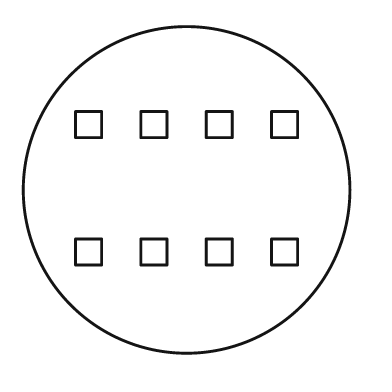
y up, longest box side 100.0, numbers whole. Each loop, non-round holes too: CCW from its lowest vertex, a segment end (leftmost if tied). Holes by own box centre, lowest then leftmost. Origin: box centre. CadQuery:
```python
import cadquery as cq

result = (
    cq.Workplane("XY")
    .moveTo(0.0, 0.0)
    .circle(50.0)
    .moveTo(-34.0, -23.0)
    .lineTo(-26.0, -23.0)
    .lineTo(-26.0, -15.0)
    .lineTo(-34.0, -15.0)
    .close()
    .moveTo(-14.0, -23.0)
    .lineTo(-6.0, -23.0)
    .lineTo(-6.0, -15.0)
    .lineTo(-14.0, -15.0)
    .close()
    .moveTo(6.0, -23.0)
    .lineTo(14.0, -23.0)
    .lineTo(14.0, -15.0)
    .lineTo(6.0, -15.0)
    .close()
    .moveTo(26.0, -23.0)
    .lineTo(34.0, -23.0)
    .lineTo(34.0, -15.0)
    .lineTo(26.0, -15.0)
    .close()
    .moveTo(-34.0, 16.0)
    .lineTo(-26.0, 16.0)
    .lineTo(-26.0, 24.0)
    .lineTo(-34.0, 24.0)
    .close()
    .moveTo(-14.0, 16.0)
    .lineTo(-6.0, 16.0)
    .lineTo(-6.0, 24.0)
    .lineTo(-14.0, 24.0)
    .close()
    .moveTo(6.0, 16.0)
    .lineTo(14.0, 16.0)
    .lineTo(14.0, 24.0)
    .lineTo(6.0, 24.0)
    .close()
    .moveTo(26.0, 16.0)
    .lineTo(34.0, 16.0)
    .lineTo(34.0, 24.0)
    .lineTo(26.0, 24.0)
    .close()
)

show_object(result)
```